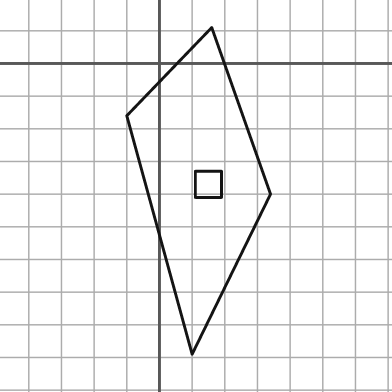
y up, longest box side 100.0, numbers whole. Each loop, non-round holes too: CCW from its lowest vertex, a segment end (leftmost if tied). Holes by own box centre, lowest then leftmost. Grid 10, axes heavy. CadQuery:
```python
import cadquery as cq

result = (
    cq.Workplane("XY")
    .moveTo(10.0, -89.0)
    .lineTo(34.0, -40.0)
    .lineTo(16.0, 11.0)
    .lineTo(-10.0, -16.0)
    .close()
    .moveTo(11.0, -41.0)
    .lineTo(19.0, -41.0)
    .lineTo(19.0, -33.0)
    .lineTo(11.0, -33.0)
    .close()
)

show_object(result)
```